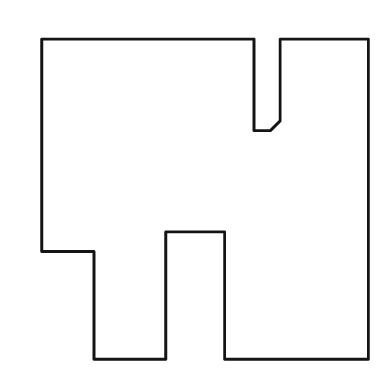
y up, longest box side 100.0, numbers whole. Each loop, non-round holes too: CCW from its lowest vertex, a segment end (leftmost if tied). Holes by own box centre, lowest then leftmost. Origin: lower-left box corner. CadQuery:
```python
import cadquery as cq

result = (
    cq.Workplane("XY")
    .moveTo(16.0, 0.0)
    .lineTo(38.0, 0.0)
    .lineTo(38.0, 39.0)
    .lineTo(56.0, 39.0)
    .lineTo(56.0, 0.0)
    .lineTo(100.0, 0.0)
    .lineTo(100.0, 98.0)
    .lineTo(73.0, 98.0)
    .lineTo(73.0, 73.0)
    .lineTo(70.0, 70.0)
    .lineTo(65.0, 70.0)
    .lineTo(65.0, 98.0)
    .lineTo(0.0, 98.0)
    .lineTo(0.0, 33.0)
    .lineTo(16.0, 33.0)
    .close()
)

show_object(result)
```